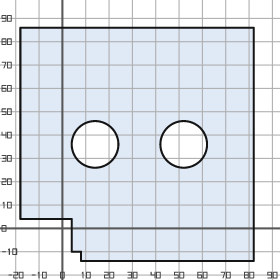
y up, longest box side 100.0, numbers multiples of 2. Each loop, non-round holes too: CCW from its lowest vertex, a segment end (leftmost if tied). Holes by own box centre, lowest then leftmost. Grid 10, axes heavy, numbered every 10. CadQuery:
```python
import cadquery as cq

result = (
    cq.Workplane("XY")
    .moveTo(8.0, -14.0)
    .lineTo(82.0, -14.0)
    .lineTo(82.0, 86.0)
    .lineTo(-18.0, 86.0)
    .lineTo(-18.0, 4.0)
    .lineTo(4.0, 4.0)
    .lineTo(4.0, -10.0)
    .lineTo(8.0, -10.0)
    .close()
    .moveTo(14.0, 36.0)
    .circle(10.0)
    .moveTo(52.0, 36.0)
    .circle(10.0)
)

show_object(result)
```